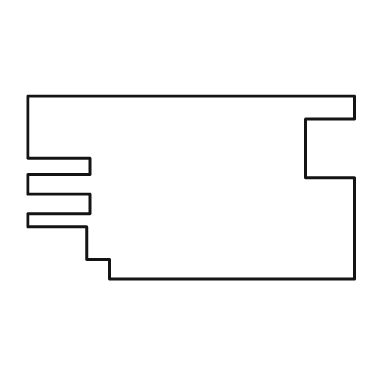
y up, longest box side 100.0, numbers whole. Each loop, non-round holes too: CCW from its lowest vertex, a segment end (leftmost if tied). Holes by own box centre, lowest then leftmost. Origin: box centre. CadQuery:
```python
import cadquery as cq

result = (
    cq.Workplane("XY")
    .moveTo(-25.0, -28.0)
    .lineTo(50.0, -28.0)
    .lineTo(50.0, 3.0)
    .lineTo(35.0, 3.0)
    .lineTo(35.0, 21.0)
    .lineTo(50.0, 21.0)
    .lineTo(50.0, 28.0)
    .lineTo(-50.0, 28.0)
    .lineTo(-50.0, 9.0)
    .lineTo(-31.0, 9.0)
    .lineTo(-31.0, 4.0)
    .lineTo(-50.0, 4.0)
    .lineTo(-50.0, -2.0)
    .lineTo(-31.0, -2.0)
    .lineTo(-31.0, -8.0)
    .lineTo(-50.0, -8.0)
    .lineTo(-50.0, -12.0)
    .lineTo(-32.0, -12.0)
    .lineTo(-32.0, -22.0)
    .lineTo(-25.0, -22.0)
    .close()
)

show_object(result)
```